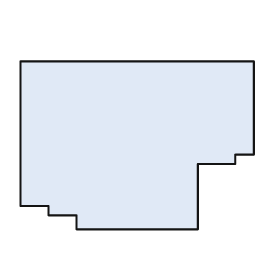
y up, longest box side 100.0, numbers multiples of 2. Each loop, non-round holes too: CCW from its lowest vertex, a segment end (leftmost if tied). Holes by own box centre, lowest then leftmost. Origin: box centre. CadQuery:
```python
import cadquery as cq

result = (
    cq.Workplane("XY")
    .moveTo(-26.0, -36.0)
    .lineTo(26.0, -36.0)
    .lineTo(26.0, -8.0)
    .lineTo(42.0, -8.0)
    .lineTo(42.0, -4.0)
    .lineTo(50.0, -4.0)
    .lineTo(50.0, 36.0)
    .lineTo(-50.0, 36.0)
    .lineTo(-50.0, -26.0)
    .lineTo(-38.0, -26.0)
    .lineTo(-38.0, -30.0)
    .lineTo(-26.0, -30.0)
    .close()
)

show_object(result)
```